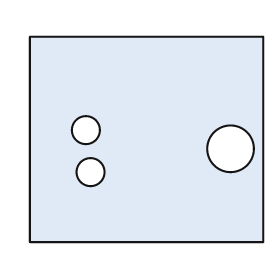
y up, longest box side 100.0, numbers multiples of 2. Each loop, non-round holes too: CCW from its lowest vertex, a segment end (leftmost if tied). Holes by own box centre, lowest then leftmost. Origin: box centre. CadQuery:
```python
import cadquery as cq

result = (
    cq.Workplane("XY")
    .moveTo(-50.0, -44.0)
    .lineTo(50.0, -44.0)
    .lineTo(50.0, 44.0)
    .lineTo(-50.0, 44.0)
    .close()
    .moveTo(-24.0, -14.0)
    .circle(6.0)
    .moveTo(36.0, -4.0)
    .circle(10.0)
    .moveTo(-26.0, 4.0)
    .circle(6.0)
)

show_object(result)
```